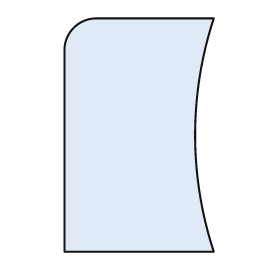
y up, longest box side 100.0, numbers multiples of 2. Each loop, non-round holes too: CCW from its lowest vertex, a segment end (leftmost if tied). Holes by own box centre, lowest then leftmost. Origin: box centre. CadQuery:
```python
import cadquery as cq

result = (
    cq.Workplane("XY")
    .moveTo(-32.0, -50.0)
    .lineTo(32.0, -50.0)
    .threePointArc((24.0, 0.0), (32.0, 50.0))
    .lineTo(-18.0, 50.0)
    .threePointArc((-28.0, 46.0), (-32.0, 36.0))
    .close()
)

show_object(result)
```